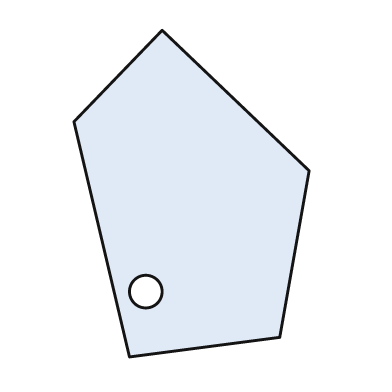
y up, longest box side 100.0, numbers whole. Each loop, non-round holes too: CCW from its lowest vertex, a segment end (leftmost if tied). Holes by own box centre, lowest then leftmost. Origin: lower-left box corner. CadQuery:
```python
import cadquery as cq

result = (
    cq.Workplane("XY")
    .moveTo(17.0, 0.0)
    .lineTo(63.0, 6.0)
    .lineTo(72.0, 57.0)
    .lineTo(27.0, 100.0)
    .lineTo(0.0, 72.0)
    .close()
    .moveTo(22.0, 20.0)
    .circle(5.0)
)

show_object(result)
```